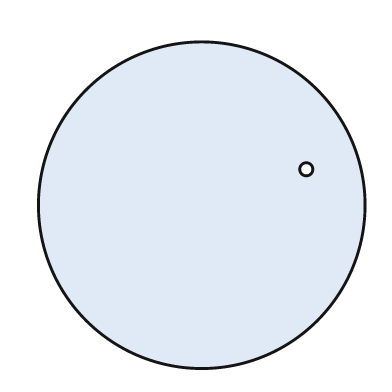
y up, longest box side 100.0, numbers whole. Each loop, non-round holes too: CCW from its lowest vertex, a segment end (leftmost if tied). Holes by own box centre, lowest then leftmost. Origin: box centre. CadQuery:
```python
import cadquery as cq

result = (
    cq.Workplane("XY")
    .moveTo(0.0, 0.0)
    .circle(50.0)
    .moveTo(32.0, 11.0)
    .circle(2.0)
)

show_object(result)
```